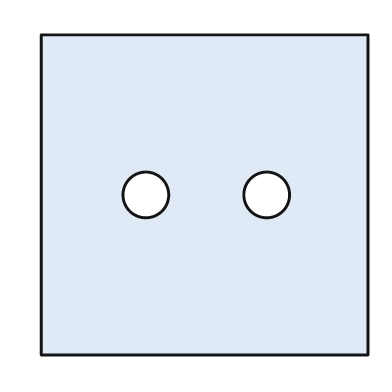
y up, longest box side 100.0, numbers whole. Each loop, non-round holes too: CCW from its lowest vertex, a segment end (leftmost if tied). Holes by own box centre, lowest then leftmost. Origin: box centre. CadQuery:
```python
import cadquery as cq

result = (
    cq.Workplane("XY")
    .moveTo(-50.0, -49.0)
    .lineTo(50.0, -49.0)
    .lineTo(50.0, 49.0)
    .lineTo(-50.0, 49.0)
    .close()
    .moveTo(-18.0, 0.0)
    .circle(7.0)
    .moveTo(19.0, 0.0)
    .circle(7.0)
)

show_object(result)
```